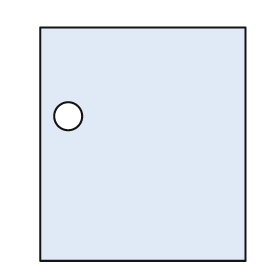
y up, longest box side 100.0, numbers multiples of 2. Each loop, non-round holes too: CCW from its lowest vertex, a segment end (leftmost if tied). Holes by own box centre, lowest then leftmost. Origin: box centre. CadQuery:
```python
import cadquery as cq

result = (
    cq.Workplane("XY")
    .moveTo(-44.0, -50.0)
    .lineTo(44.0, -50.0)
    .lineTo(44.0, 50.0)
    .lineTo(-44.0, 50.0)
    .close()
    .moveTo(-32.0, 12.0)
    .circle(6.0)
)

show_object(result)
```